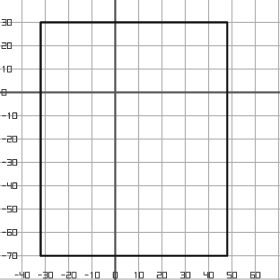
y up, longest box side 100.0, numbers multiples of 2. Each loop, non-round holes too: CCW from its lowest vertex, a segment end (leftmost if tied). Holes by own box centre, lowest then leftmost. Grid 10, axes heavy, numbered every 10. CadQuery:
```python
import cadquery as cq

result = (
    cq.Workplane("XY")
    .moveTo(-32.0, -70.0)
    .lineTo(48.0, -70.0)
    .lineTo(48.0, 30.0)
    .lineTo(-32.0, 30.0)
    .close()
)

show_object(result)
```